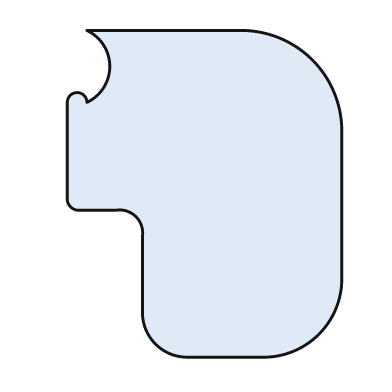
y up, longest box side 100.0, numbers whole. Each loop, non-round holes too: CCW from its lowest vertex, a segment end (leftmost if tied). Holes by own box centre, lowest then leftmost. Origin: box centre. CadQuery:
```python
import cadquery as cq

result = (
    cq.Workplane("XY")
    .moveTo(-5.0, -50.0)
    .lineTo(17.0, -50.0)
    .threePointArc((35.0, -43.0), (42.0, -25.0))
    .lineTo(42.0, 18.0)
    .threePointArc((33.0, 41.0), (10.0, 50.0))
    .lineTo(-36.0, 50.0)
    .threePointArc((-29.0, 39.0), (-36.0, 28.0))
    .threePointArc((-39.0, 31.0), (-42.0, 28.0))
    .lineTo(-42.0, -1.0)
    .threePointArc((-41.0, -4.0), (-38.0, -5.0))
    .lineTo(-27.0, -5.0)
    .threePointArc((-21.0, -7.0), (-19.0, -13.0))
    .lineTo(-19.0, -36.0)
    .threePointArc((-15.0, -46.0), (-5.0, -50.0))
    .close()
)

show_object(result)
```